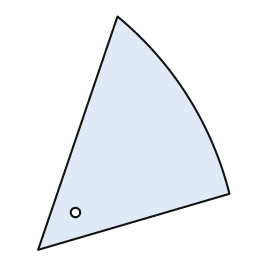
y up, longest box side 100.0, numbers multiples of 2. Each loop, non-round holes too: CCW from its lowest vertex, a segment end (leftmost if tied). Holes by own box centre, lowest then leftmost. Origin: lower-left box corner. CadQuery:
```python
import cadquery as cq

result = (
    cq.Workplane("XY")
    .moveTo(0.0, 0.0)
    .lineTo(82.0, 24.0)
    .threePointArc((64.0, 66.0), (34.0, 100.0))
    .close()
    .moveTo(16.0, 16.0)
    .circle(2.0)
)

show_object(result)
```